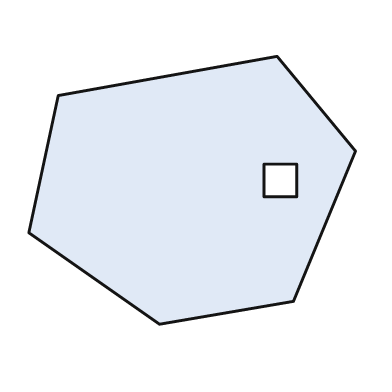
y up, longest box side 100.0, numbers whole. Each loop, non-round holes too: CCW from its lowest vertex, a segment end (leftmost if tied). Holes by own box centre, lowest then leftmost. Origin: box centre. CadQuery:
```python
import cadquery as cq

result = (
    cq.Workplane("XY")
    .moveTo(-10.0, -41.0)
    .lineTo(31.0, -34.0)
    .lineTo(50.0, 12.0)
    .lineTo(26.0, 41.0)
    .lineTo(-41.0, 29.0)
    .lineTo(-50.0, -13.0)
    .close()
    .moveTo(22.0, -2.0)
    .lineTo(32.0, -2.0)
    .lineTo(32.0, 8.0)
    .lineTo(22.0, 8.0)
    .close()
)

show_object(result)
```